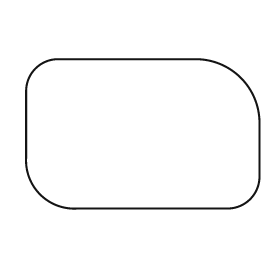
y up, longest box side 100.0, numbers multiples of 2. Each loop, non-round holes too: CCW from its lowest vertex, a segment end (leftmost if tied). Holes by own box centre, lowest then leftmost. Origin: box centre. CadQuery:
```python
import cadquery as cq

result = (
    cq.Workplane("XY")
    .moveTo(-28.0, -32.0)
    .lineTo(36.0, -32.0)
    .threePointArc((46.0, -28.0), (50.0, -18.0))
    .lineTo(50.0, 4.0)
    .threePointArc((42.0, 24.0), (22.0, 32.0))
    .lineTo(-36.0, 32.0)
    .threePointArc((-46.0, 28.0), (-50.0, 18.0))
    .lineTo(-50.0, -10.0)
    .threePointArc((-44.0, -26.0), (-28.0, -32.0))
    .close()
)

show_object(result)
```